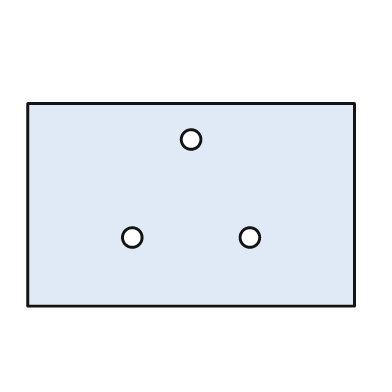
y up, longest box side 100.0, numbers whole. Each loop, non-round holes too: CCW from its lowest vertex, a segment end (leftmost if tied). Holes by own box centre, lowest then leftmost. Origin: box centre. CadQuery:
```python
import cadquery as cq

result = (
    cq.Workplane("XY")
    .moveTo(-50.0, -31.0)
    .lineTo(50.0, -31.0)
    .lineTo(50.0, 31.0)
    .lineTo(-50.0, 31.0)
    .close()
    .moveTo(-18.0, -10.0)
    .circle(3.0)
    .moveTo(18.0, -10.0)
    .circle(3.0)
    .moveTo(0.0, 20.0)
    .circle(3.0)
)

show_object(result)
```